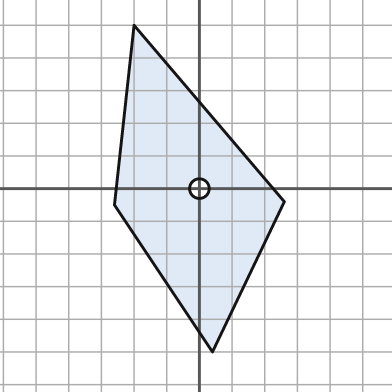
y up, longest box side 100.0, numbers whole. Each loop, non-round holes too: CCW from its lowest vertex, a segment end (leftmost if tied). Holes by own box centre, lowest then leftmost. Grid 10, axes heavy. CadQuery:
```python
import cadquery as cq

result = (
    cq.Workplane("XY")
    .moveTo(4.0, -50.0)
    .lineTo(26.0, -4.0)
    .lineTo(-20.0, 50.0)
    .lineTo(-26.0, -5.0)
    .close()
    .moveTo(0.0, 0.0)
    .circle(3.0)
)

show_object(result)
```